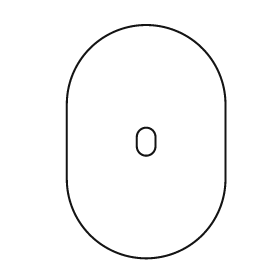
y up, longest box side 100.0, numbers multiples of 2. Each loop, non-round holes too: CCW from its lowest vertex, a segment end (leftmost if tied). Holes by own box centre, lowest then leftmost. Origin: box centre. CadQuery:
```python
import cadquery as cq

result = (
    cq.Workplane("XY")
    .moveTo(-34.0, -16.0)
    .threePointArc((0.0, -50.0), (34.0, -16.0))
    .lineTo(34.0, 16.0)
    .threePointArc((0.0, 50.0), (-34.0, 16.0))
    .close()
    .moveTo(-4.0, -2.0)
    .threePointArc((0.0, -6.0), (4.0, -2.0))
    .lineTo(4.0, 2.0)
    .threePointArc((0.0, 6.0), (-4.0, 2.0))
    .close()
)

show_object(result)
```